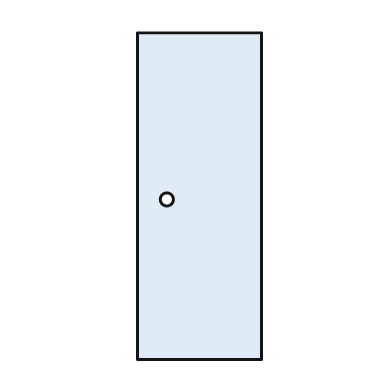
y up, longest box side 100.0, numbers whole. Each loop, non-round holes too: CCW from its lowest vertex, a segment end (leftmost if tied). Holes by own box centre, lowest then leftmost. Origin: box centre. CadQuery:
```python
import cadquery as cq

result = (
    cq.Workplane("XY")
    .moveTo(-19.0, -50.0)
    .lineTo(19.0, -50.0)
    .lineTo(19.0, 50.0)
    .lineTo(-19.0, 50.0)
    .close()
    .moveTo(-10.0, -1.0)
    .circle(2.0)
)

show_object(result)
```